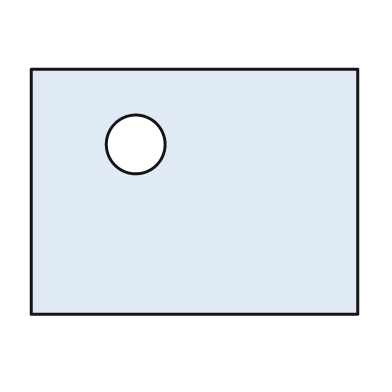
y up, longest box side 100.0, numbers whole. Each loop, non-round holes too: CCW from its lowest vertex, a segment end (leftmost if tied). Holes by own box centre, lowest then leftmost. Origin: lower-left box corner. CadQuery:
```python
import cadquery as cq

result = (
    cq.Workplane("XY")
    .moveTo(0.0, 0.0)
    .lineTo(100.0, 0.0)
    .lineTo(100.0, 75.0)
    .lineTo(0.0, 75.0)
    .close()
    .moveTo(32.0, 52.0)
    .circle(9.0)
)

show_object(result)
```